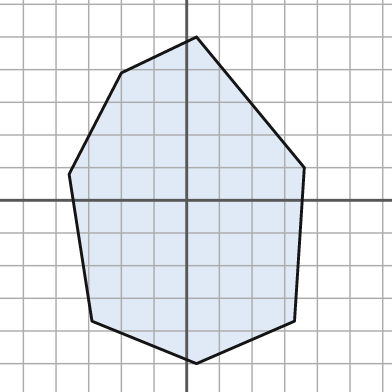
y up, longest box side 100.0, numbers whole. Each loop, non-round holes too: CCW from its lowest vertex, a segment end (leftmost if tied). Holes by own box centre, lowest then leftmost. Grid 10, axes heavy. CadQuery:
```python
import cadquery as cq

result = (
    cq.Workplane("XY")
    .moveTo(3.0, -50.0)
    .lineTo(33.0, -37.0)
    .lineTo(36.0, 10.0)
    .lineTo(3.0, 50.0)
    .lineTo(-20.0, 39.0)
    .lineTo(-36.0, 8.0)
    .lineTo(-29.0, -37.0)
    .close()
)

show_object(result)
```